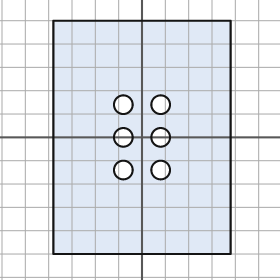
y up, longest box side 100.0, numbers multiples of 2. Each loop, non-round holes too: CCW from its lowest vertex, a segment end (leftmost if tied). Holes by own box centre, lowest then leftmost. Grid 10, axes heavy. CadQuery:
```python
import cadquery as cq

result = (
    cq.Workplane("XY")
    .moveTo(-38.0, -50.0)
    .lineTo(38.0, -50.0)
    .lineTo(38.0, 50.0)
    .lineTo(-38.0, 50.0)
    .close()
    .moveTo(-8.0, -14.0)
    .circle(4.0)
    .moveTo(8.0, -14.0)
    .circle(4.0)
    .moveTo(-8.0, 0.0)
    .circle(4.0)
    .moveTo(8.0, 0.0)
    .circle(4.0)
    .moveTo(-8.0, 14.0)
    .circle(4.0)
    .moveTo(8.0, 14.0)
    .circle(4.0)
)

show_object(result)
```